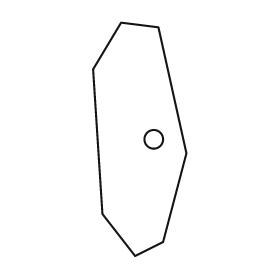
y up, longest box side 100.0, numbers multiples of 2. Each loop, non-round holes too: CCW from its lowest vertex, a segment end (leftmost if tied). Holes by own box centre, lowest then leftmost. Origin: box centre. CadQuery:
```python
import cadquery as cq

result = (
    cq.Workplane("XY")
    .moveTo(-2.0, -50.0)
    .lineTo(10.0, -44.0)
    .lineTo(20.0, -6.0)
    .lineTo(8.0, 48.0)
    .lineTo(-8.0, 50.0)
    .lineTo(-20.0, 30.0)
    .lineTo(-16.0, -32.0)
    .close()
    .moveTo(6.0, 0.0)
    .circle(4.0)
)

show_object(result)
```